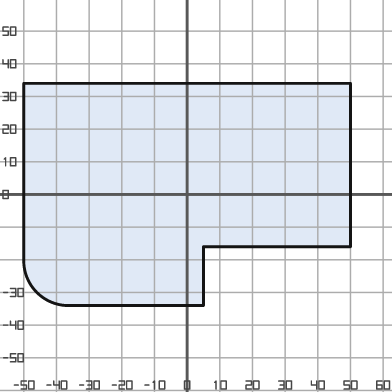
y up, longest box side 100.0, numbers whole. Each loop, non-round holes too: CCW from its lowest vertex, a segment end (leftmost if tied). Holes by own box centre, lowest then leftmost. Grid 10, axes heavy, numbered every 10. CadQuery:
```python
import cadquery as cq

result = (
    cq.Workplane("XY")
    .moveTo(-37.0, -34.0)
    .lineTo(5.0, -34.0)
    .lineTo(5.0, -16.0)
    .lineTo(50.0, -16.0)
    .lineTo(50.0, 34.0)
    .lineTo(-50.0, 34.0)
    .lineTo(-50.0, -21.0)
    .threePointArc((-46.0, -30.0), (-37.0, -34.0))
    .close()
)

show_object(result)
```